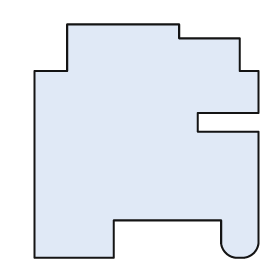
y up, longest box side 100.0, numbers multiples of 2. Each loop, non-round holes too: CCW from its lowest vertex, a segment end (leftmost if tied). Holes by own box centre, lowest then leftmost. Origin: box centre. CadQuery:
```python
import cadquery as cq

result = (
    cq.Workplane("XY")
    .moveTo(-48.0, -50.0)
    .lineTo(-14.0, -50.0)
    .lineTo(-14.0, -34.0)
    .lineTo(32.0, -34.0)
    .lineTo(32.0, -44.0)
    .threePointArc((34.0, -48.0), (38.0, -50.0))
    .lineTo(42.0, -50.0)
    .threePointArc((46.0, -48.0), (48.0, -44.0))
    .lineTo(48.0, 4.0)
    .lineTo(22.0, 4.0)
    .lineTo(22.0, 12.0)
    .lineTo(48.0, 12.0)
    .lineTo(48.0, 30.0)
    .lineTo(40.0, 30.0)
    .lineTo(40.0, 44.0)
    .lineTo(14.0, 44.0)
    .lineTo(14.0, 50.0)
    .lineTo(-34.0, 50.0)
    .lineTo(-34.0, 30.0)
    .lineTo(-48.0, 30.0)
    .close()
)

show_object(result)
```